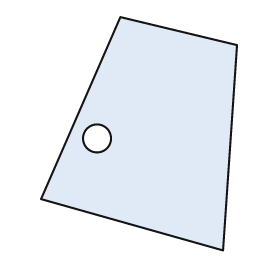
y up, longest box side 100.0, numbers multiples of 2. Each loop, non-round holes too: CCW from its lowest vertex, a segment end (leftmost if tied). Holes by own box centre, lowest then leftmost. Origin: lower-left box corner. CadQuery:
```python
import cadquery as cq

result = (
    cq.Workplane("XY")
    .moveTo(78.0, 0.0)
    .lineTo(84.0, 88.0)
    .lineTo(34.0, 100.0)
    .lineTo(0.0, 22.0)
    .close()
    .moveTo(24.0, 48.0)
    .circle(6.0)
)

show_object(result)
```